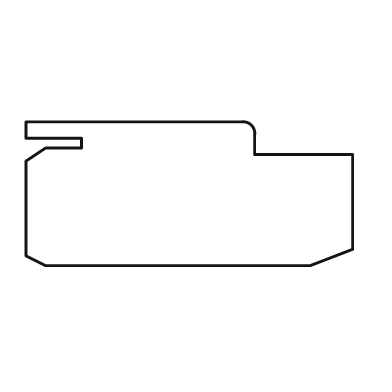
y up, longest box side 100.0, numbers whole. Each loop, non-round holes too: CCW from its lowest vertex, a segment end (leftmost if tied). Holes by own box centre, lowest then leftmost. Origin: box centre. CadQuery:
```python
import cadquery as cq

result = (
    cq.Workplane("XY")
    .moveTo(-44.0, -22.0)
    .lineTo(37.0, -22.0)
    .lineTo(50.0, -17.0)
    .lineTo(50.0, 12.0)
    .lineTo(20.0, 12.0)
    .lineTo(20.0, 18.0)
    .threePointArc((19.0, 21.0), (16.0, 22.0))
    .lineTo(-50.0, 22.0)
    .lineTo(-50.0, 17.0)
    .lineTo(-33.0, 17.0)
    .lineTo(-33.0, 14.0)
    .lineTo(-44.0, 14.0)
    .lineTo(-50.0, 10.0)
    .lineTo(-50.0, -19.0)
    .close()
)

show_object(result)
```